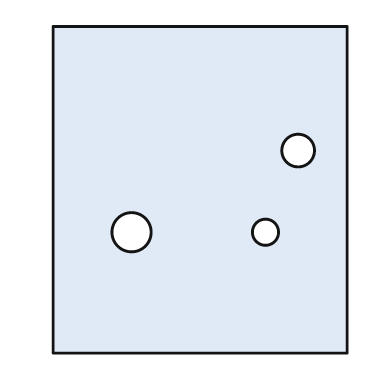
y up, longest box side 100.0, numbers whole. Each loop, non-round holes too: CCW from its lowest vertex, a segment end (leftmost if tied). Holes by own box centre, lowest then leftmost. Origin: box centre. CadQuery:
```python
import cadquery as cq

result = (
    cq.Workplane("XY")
    .moveTo(-45.0, -50.0)
    .lineTo(45.0, -50.0)
    .lineTo(45.0, 50.0)
    .lineTo(-45.0, 50.0)
    .close()
    .moveTo(-21.0, -13.0)
    .circle(6.0)
    .moveTo(20.0, -13.0)
    .circle(4.0)
    .moveTo(30.0, 12.0)
    .circle(5.0)
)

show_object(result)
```